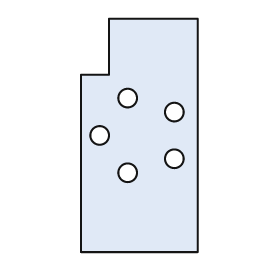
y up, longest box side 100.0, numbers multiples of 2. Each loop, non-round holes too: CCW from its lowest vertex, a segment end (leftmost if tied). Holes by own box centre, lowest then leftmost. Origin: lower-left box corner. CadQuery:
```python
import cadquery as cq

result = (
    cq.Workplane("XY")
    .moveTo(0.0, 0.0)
    .lineTo(50.0, 0.0)
    .lineTo(50.0, 100.0)
    .lineTo(12.0, 100.0)
    .lineTo(12.0, 76.0)
    .lineTo(0.0, 76.0)
    .close()
    .moveTo(20.0, 34.0)
    .circle(4.0)
    .moveTo(40.0, 40.0)
    .circle(4.0)
    .moveTo(8.0, 50.0)
    .circle(4.0)
    .moveTo(40.0, 60.0)
    .circle(4.0)
    .moveTo(20.0, 66.0)
    .circle(4.0)
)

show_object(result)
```